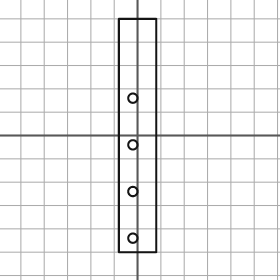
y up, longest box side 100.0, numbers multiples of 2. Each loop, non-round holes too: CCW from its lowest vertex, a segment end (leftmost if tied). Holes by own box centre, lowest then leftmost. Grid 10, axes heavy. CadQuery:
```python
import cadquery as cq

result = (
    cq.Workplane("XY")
    .moveTo(-8.0, -50.0)
    .lineTo(8.0, -50.0)
    .lineTo(8.0, 50.0)
    .lineTo(-8.0, 50.0)
    .close()
    .moveTo(-2.0, -44.0)
    .circle(2.0)
    .moveTo(-2.0, -24.0)
    .circle(2.0)
    .moveTo(-2.0, -4.0)
    .circle(2.0)
    .moveTo(-2.0, 16.0)
    .circle(2.0)
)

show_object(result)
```